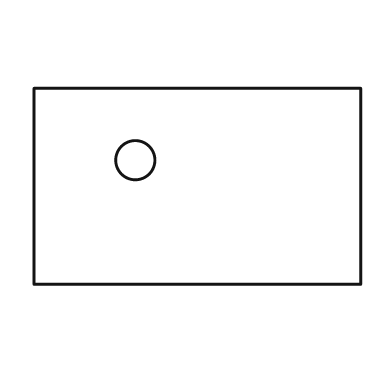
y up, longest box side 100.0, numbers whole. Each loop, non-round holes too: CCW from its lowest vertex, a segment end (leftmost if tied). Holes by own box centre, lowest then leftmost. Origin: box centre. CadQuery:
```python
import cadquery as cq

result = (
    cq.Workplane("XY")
    .moveTo(-50.0, -30.0)
    .lineTo(50.0, -30.0)
    .lineTo(50.0, 30.0)
    .lineTo(-50.0, 30.0)
    .close()
    .moveTo(-19.0, 8.0)
    .circle(6.0)
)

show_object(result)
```